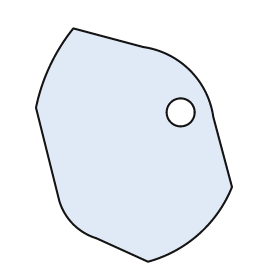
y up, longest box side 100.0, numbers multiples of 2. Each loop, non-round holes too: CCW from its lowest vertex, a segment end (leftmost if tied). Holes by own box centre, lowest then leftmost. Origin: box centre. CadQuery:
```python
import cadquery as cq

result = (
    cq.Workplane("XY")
    .moveTo(6.0, -50.0)
    .threePointArc((28.0, -38.0), (42.0, -18.0))
    .lineTo(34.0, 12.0)
    .threePointArc((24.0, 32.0), (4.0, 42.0))
    .lineTo(-26.0, 50.0)
    .threePointArc((-36.0, 34.0), (-42.0, 16.0))
    .lineTo(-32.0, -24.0)
    .threePointArc((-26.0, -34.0), (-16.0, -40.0))
    .close()
    .moveTo(20.0, 14.0)
    .circle(6.0)
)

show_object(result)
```